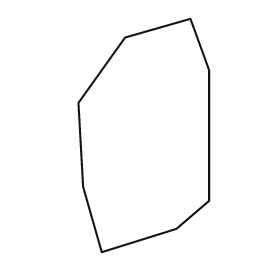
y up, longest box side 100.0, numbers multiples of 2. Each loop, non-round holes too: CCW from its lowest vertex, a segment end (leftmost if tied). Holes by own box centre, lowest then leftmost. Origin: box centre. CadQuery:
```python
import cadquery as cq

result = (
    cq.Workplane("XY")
    .moveTo(-18.0, -50.0)
    .lineTo(14.0, -40.0)
    .lineTo(28.0, -28.0)
    .lineTo(28.0, 28.0)
    .lineTo(20.0, 50.0)
    .lineTo(-8.0, 42.0)
    .lineTo(-28.0, 14.0)
    .lineTo(-26.0, -22.0)
    .close()
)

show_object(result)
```